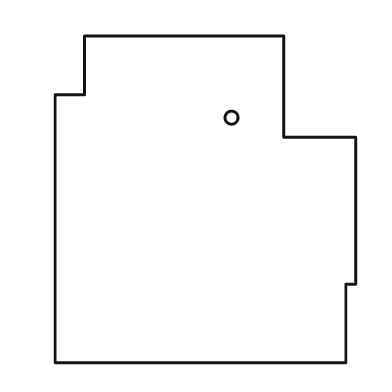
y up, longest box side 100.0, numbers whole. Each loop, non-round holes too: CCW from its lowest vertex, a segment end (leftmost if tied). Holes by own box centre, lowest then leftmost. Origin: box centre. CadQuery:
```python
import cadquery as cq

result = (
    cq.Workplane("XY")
    .moveTo(-46.0, -50.0)
    .lineTo(43.0, -50.0)
    .lineTo(43.0, -26.0)
    .lineTo(46.0, -26.0)
    .lineTo(46.0, 19.0)
    .lineTo(24.0, 19.0)
    .lineTo(24.0, 50.0)
    .lineTo(-37.0, 50.0)
    .lineTo(-37.0, 32.0)
    .lineTo(-46.0, 32.0)
    .close()
    .moveTo(8.0, 25.0)
    .circle(2.0)
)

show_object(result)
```